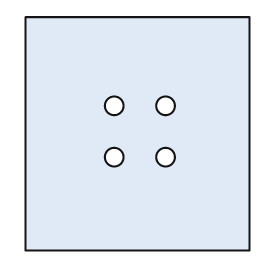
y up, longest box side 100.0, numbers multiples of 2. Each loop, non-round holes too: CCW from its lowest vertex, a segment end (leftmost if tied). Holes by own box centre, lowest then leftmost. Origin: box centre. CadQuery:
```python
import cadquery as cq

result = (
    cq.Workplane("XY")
    .moveTo(-48.0, -50.0)
    .lineTo(48.0, -50.0)
    .lineTo(48.0, 50.0)
    .lineTo(-48.0, 50.0)
    .close()
    .moveTo(-10.0, -10.0)
    .circle(4.0)
    .moveTo(12.0, -10.0)
    .circle(4.0)
    .moveTo(-10.0, 12.0)
    .circle(4.0)
    .moveTo(12.0, 12.0)
    .circle(4.0)
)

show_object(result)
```